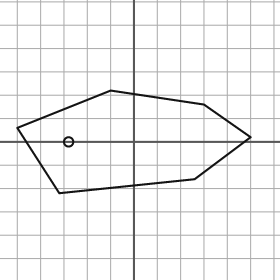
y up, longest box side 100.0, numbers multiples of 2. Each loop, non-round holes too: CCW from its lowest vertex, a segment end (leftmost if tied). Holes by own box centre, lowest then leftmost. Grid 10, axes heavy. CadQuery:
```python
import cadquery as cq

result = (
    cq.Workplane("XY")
    .moveTo(-32.0, -22.0)
    .lineTo(26.0, -16.0)
    .lineTo(50.0, 2.0)
    .lineTo(30.0, 16.0)
    .lineTo(-10.0, 22.0)
    .lineTo(-50.0, 6.0)
    .close()
    .moveTo(-28.0, 0.0)
    .circle(2.0)
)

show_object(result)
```